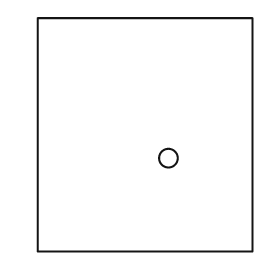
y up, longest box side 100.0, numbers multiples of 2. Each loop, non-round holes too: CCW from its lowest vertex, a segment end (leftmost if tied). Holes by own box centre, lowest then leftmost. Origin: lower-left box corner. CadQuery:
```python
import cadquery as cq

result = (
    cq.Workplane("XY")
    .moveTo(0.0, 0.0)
    .lineTo(92.0, 0.0)
    .lineTo(92.0, 100.0)
    .lineTo(0.0, 100.0)
    .close()
    .moveTo(56.0, 40.0)
    .circle(4.0)
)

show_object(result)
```